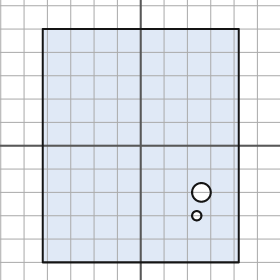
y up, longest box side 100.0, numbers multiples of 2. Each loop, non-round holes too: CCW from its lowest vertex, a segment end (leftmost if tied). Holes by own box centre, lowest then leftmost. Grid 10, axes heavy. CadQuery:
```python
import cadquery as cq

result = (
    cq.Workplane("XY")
    .moveTo(-42.0, -50.0)
    .lineTo(42.0, -50.0)
    .lineTo(42.0, 50.0)
    .lineTo(-42.0, 50.0)
    .close()
    .moveTo(24.0, -30.0)
    .circle(2.0)
    .moveTo(26.0, -20.0)
    .circle(4.0)
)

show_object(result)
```